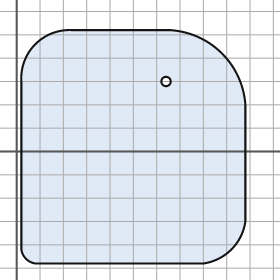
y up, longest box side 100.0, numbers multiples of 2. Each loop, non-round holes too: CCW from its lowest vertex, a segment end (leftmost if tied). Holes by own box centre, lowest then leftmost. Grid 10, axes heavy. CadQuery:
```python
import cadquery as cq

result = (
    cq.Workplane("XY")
    .moveTo(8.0, -48.0)
    .lineTo(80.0, -48.0)
    .threePointArc((92.0, -42.0), (98.0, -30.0))
    .lineTo(98.0, 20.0)
    .threePointArc((88.0, 42.0), (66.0, 52.0))
    .lineTo(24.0, 52.0)
    .threePointArc((8.0, 46.0), (2.0, 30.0))
    .lineTo(2.0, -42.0)
    .threePointArc((4.0, -46.0), (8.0, -48.0))
    .close()
    .moveTo(64.0, 30.0)
    .circle(2.0)
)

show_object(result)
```